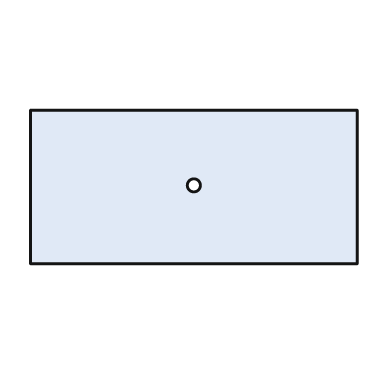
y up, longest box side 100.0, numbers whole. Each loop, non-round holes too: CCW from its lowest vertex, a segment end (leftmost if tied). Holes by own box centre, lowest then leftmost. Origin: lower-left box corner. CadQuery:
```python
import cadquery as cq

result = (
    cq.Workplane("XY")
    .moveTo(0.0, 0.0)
    .lineTo(100.0, 0.0)
    .lineTo(100.0, 47.0)
    .lineTo(0.0, 47.0)
    .close()
    .moveTo(50.0, 24.0)
    .circle(2.0)
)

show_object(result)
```